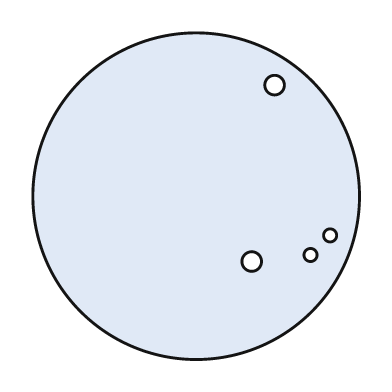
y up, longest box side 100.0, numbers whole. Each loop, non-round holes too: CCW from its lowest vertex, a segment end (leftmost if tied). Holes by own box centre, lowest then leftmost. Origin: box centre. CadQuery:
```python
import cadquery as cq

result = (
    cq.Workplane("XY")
    .moveTo(0.0, 0.0)
    .circle(50.0)
    .moveTo(17.0, -20.0)
    .circle(3.0)
    .moveTo(35.0, -18.0)
    .circle(2.0)
    .moveTo(41.0, -12.0)
    .circle(2.0)
    .moveTo(24.0, 34.0)
    .circle(3.0)
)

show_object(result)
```